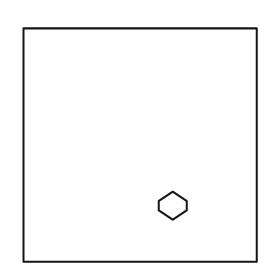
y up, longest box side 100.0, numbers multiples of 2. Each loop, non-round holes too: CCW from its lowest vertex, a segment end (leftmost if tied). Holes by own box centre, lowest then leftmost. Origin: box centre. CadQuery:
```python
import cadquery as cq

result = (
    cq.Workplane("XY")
    .moveTo(-50.0, -50.0)
    .lineTo(50.0, -50.0)
    .lineTo(50.0, 50.0)
    .lineTo(-50.0, 50.0)
    .close()
    .moveTo(14.0, -32.0)
    .lineTo(20.0, -28.0)
    .lineTo(20.0, -24.0)
    .lineTo(14.0, -20.0)
    .lineTo(8.0, -24.0)
    .lineTo(8.0, -28.0)
    .close()
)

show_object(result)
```